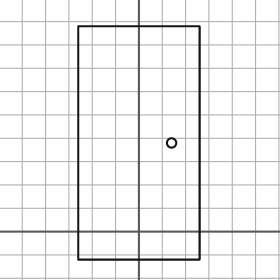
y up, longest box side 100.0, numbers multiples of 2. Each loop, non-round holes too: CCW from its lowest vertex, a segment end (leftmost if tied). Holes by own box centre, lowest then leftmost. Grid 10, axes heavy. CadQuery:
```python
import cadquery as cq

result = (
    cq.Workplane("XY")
    .moveTo(-26.0, -12.0)
    .lineTo(26.0, -12.0)
    .lineTo(26.0, 88.0)
    .lineTo(-26.0, 88.0)
    .close()
    .moveTo(14.0, 38.0)
    .circle(2.0)
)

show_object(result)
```